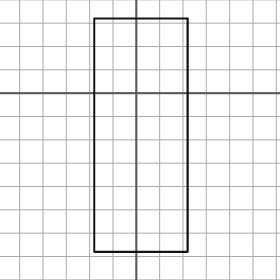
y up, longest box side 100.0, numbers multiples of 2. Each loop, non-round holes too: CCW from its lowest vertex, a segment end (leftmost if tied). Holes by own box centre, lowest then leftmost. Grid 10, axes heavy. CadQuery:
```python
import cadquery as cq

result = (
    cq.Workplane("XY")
    .moveTo(-18.0, -68.0)
    .lineTo(22.0, -68.0)
    .lineTo(22.0, 32.0)
    .lineTo(-18.0, 32.0)
    .close()
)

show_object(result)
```